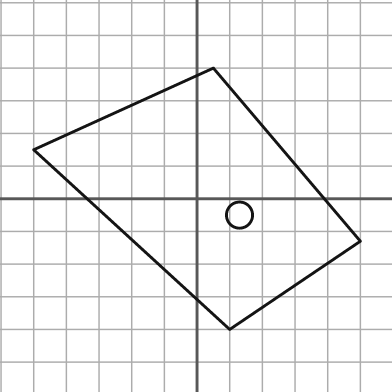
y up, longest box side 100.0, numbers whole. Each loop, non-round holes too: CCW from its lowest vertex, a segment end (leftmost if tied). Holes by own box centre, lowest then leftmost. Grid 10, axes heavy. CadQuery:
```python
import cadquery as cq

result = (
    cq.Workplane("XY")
    .moveTo(10.0, -40.0)
    .lineTo(50.0, -13.0)
    .lineTo(5.0, 40.0)
    .lineTo(-50.0, 15.0)
    .close()
    .moveTo(13.0, -5.0)
    .circle(4.0)
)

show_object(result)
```